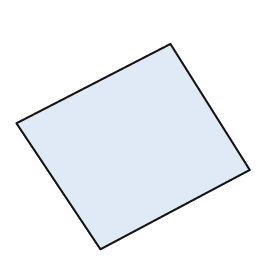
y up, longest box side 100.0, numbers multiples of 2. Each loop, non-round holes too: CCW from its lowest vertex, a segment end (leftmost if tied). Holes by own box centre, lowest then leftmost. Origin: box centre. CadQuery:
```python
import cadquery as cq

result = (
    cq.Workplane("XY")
    .moveTo(-14.0, -44.0)
    .lineTo(50.0, -10.0)
    .lineTo(16.0, 44.0)
    .lineTo(-50.0, 10.0)
    .close()
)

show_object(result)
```